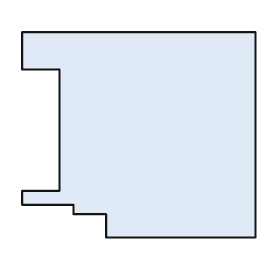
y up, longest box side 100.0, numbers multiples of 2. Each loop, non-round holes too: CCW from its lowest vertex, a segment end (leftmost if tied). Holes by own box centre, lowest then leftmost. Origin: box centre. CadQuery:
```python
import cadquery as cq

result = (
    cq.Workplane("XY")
    .moveTo(-14.0, -44.0)
    .lineTo(50.0, -44.0)
    .lineTo(50.0, 44.0)
    .lineTo(-50.0, 44.0)
    .lineTo(-50.0, 28.0)
    .lineTo(-34.0, 28.0)
    .lineTo(-34.0, -24.0)
    .lineTo(-50.0, -24.0)
    .lineTo(-50.0, -30.0)
    .lineTo(-28.0, -30.0)
    .lineTo(-28.0, -34.0)
    .lineTo(-14.0, -34.0)
    .close()
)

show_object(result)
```